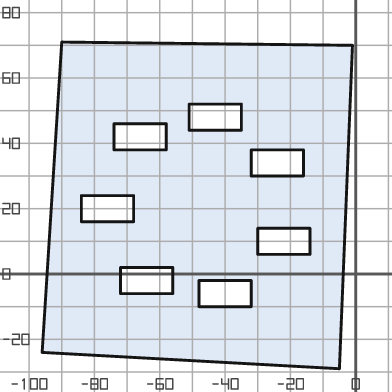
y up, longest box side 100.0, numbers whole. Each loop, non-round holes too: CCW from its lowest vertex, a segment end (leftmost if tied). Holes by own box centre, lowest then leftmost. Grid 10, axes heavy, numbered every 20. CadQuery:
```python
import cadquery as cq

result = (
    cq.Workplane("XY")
    .moveTo(-5.0, -29.0)
    .lineTo(-1.0, 70.0)
    .lineTo(-90.0, 71.0)
    .lineTo(-96.0, -24.0)
    .close()
    .moveTo(-48.0, -10.0)
    .lineTo(-32.0, -10.0)
    .lineTo(-32.0, -2.0)
    .lineTo(-48.0, -2.0)
    .close()
    .moveTo(-72.0, -6.0)
    .lineTo(-56.0, -6.0)
    .lineTo(-56.0, 2.0)
    .lineTo(-72.0, 2.0)
    .close()
    .moveTo(-30.0, 6.0)
    .lineTo(-14.0, 6.0)
    .lineTo(-14.0, 14.0)
    .lineTo(-30.0, 14.0)
    .close()
    .moveTo(-84.0, 16.0)
    .lineTo(-68.0, 16.0)
    .lineTo(-68.0, 24.0)
    .lineTo(-84.0, 24.0)
    .close()
    .moveTo(-32.0, 30.0)
    .lineTo(-16.0, 30.0)
    .lineTo(-16.0, 38.0)
    .lineTo(-32.0, 38.0)
    .close()
    .moveTo(-74.0, 38.0)
    .lineTo(-58.0, 38.0)
    .lineTo(-58.0, 46.0)
    .lineTo(-74.0, 46.0)
    .close()
    .moveTo(-51.0, 44.0)
    .lineTo(-35.0, 44.0)
    .lineTo(-35.0, 52.0)
    .lineTo(-51.0, 52.0)
    .close()
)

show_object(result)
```